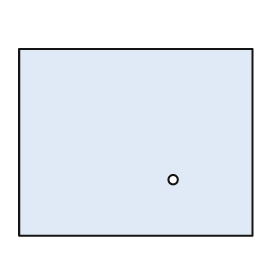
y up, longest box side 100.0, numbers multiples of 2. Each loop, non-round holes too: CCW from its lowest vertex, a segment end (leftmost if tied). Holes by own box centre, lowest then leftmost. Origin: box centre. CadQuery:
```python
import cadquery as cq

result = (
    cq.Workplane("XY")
    .moveTo(-50.0, -40.0)
    .lineTo(50.0, -40.0)
    .lineTo(50.0, 40.0)
    .lineTo(-50.0, 40.0)
    .close()
    .moveTo(16.0, -16.0)
    .circle(2.0)
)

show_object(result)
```